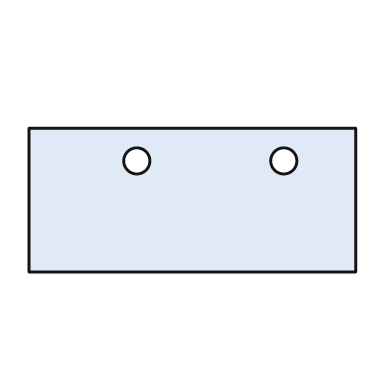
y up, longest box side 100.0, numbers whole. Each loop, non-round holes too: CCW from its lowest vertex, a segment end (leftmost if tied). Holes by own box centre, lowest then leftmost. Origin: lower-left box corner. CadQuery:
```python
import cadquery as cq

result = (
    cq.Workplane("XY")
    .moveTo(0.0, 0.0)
    .lineTo(100.0, 0.0)
    .lineTo(100.0, 44.0)
    .lineTo(0.0, 44.0)
    .close()
    .moveTo(33.0, 34.0)
    .circle(4.0)
    .moveTo(78.0, 34.0)
    .circle(4.0)
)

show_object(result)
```